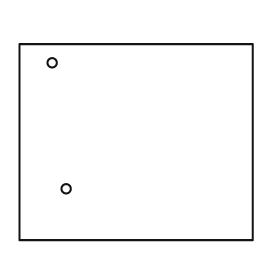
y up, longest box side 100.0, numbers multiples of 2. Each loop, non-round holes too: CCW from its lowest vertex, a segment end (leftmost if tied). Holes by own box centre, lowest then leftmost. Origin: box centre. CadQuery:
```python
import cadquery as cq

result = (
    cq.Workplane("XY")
    .moveTo(-50.0, -42.0)
    .lineTo(50.0, -42.0)
    .lineTo(50.0, 42.0)
    .lineTo(-50.0, 42.0)
    .close()
    .moveTo(-30.0, -20.0)
    .circle(2.0)
    .moveTo(-36.0, 34.0)
    .circle(2.0)
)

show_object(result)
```